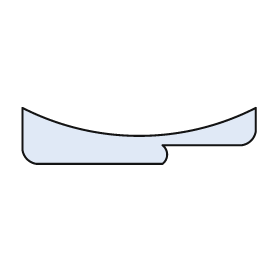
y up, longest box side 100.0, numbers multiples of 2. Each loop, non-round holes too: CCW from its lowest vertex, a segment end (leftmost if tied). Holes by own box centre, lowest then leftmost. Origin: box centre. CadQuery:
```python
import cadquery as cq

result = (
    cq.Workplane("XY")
    .moveTo(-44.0, -12.0)
    .lineTo(10.0, -12.0)
    .threePointArc((12.0, -8.0), (10.0, -4.0))
    .lineTo(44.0, -4.0)
    .threePointArc((48.0, -2.0), (50.0, 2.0))
    .lineTo(50.0, 12.0)
    .threePointArc((0.0, 0.0), (-50.0, 12.0))
    .lineTo(-50.0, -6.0)
    .threePointArc((-48.0, -10.0), (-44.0, -12.0))
    .close()
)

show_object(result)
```